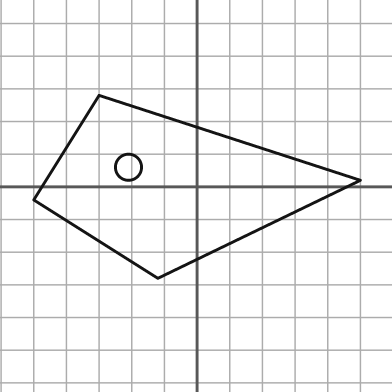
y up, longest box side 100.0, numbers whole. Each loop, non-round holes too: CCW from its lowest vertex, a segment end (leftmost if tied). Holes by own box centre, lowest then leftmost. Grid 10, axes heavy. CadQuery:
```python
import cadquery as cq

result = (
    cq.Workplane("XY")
    .moveTo(-12.0, -28.0)
    .lineTo(50.0, 2.0)
    .lineTo(-30.0, 28.0)
    .lineTo(-50.0, -4.0)
    .close()
    .moveTo(-21.0, 6.0)
    .circle(4.0)
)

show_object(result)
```